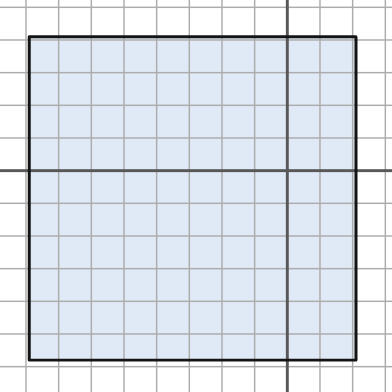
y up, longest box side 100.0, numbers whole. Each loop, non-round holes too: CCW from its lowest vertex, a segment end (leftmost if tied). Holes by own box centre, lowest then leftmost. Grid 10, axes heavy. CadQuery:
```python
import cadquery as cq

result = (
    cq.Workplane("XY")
    .moveTo(-79.0, -58.0)
    .lineTo(21.0, -58.0)
    .lineTo(21.0, 41.0)
    .lineTo(-79.0, 41.0)
    .close()
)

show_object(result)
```